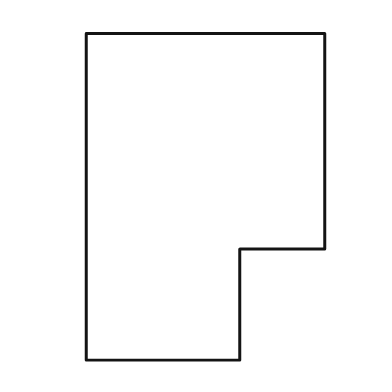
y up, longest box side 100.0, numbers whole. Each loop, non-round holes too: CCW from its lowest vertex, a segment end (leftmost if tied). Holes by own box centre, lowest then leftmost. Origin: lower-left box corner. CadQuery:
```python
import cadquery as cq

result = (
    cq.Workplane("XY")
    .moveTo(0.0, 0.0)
    .lineTo(47.0, 0.0)
    .lineTo(47.0, 34.0)
    .lineTo(73.0, 34.0)
    .lineTo(73.0, 100.0)
    .lineTo(0.0, 100.0)
    .close()
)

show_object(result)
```